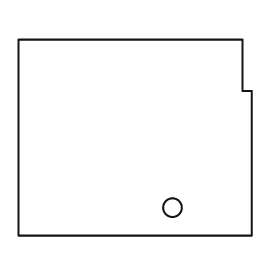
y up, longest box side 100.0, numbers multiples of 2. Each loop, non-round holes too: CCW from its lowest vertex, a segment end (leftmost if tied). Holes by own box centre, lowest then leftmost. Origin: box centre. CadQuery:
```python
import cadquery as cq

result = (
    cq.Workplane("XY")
    .moveTo(-50.0, -42.0)
    .lineTo(50.0, -42.0)
    .lineTo(50.0, 20.0)
    .lineTo(46.0, 20.0)
    .lineTo(46.0, 42.0)
    .lineTo(-50.0, 42.0)
    .close()
    .moveTo(16.0, -30.0)
    .circle(4.0)
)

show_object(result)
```